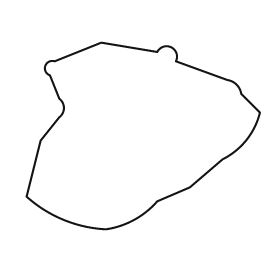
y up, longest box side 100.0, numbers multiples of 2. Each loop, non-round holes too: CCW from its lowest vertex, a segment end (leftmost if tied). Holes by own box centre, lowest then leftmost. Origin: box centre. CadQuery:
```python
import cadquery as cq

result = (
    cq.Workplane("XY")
    .moveTo(-16.0, -40.0)
    .threePointArc((-4.0, -36.0), (6.0, -28.0))
    .lineTo(20.0, -22.0)
    .lineTo(34.0, -10.0)
    .threePointArc((44.0, -2.0), (50.0, 10.0))
    .lineTo(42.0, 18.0)
    .threePointArc((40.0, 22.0), (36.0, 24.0))
    .lineTo(14.0, 32.0)
    .threePointArc((12.0, 38.0), (6.0, 36.0))
    .lineTo(-18.0, 40.0)
    .lineTo(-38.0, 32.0)
    .threePointArc((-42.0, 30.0), (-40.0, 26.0))
    .lineTo(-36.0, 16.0)
    .threePointArc((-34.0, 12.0), (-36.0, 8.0))
    .lineTo(-44.0, -2.0)
    .lineTo(-50.0, -26.0)
    .threePointArc((-34.0, -36.0), (-16.0, -40.0))
    .close()
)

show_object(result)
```